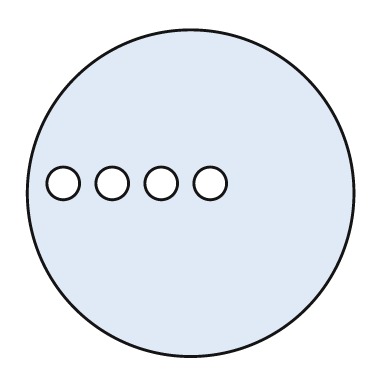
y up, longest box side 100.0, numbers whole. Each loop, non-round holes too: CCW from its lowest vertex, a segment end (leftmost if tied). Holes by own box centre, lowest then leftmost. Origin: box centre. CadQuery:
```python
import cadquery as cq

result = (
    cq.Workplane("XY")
    .moveTo(0.0, 0.0)
    .circle(50.0)
    .moveTo(-39.0, 3.0)
    .circle(5.0)
    .moveTo(-24.0, 3.0)
    .circle(5.0)
    .moveTo(-9.0, 3.0)
    .circle(5.0)
    .moveTo(6.0, 3.0)
    .circle(5.0)
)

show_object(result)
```